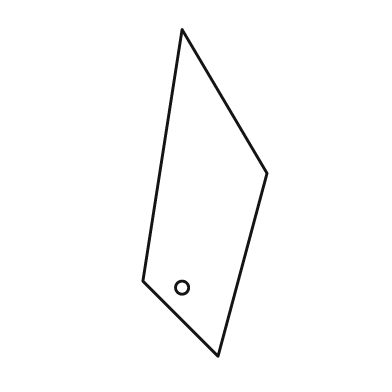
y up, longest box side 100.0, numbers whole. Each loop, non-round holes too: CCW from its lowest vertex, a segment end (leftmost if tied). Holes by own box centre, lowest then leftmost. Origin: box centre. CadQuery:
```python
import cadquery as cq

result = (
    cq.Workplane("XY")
    .moveTo(4.0, -50.0)
    .lineTo(19.0, 6.0)
    .lineTo(-7.0, 50.0)
    .lineTo(-19.0, -27.0)
    .close()
    .moveTo(-7.0, -29.0)
    .circle(2.0)
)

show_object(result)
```